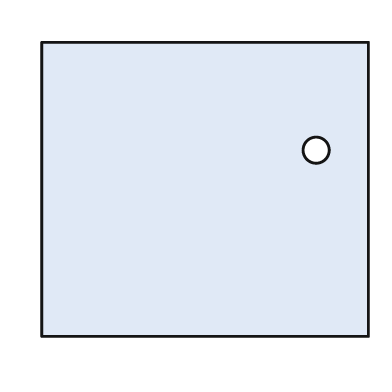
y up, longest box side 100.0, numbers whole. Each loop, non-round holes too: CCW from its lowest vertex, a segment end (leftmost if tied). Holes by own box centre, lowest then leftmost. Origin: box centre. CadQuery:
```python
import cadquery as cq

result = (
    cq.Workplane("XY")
    .moveTo(-50.0, -45.0)
    .lineTo(50.0, -45.0)
    .lineTo(50.0, 45.0)
    .lineTo(-50.0, 45.0)
    .close()
    .moveTo(34.0, 12.0)
    .circle(4.0)
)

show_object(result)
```